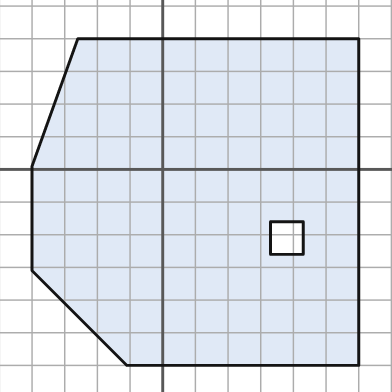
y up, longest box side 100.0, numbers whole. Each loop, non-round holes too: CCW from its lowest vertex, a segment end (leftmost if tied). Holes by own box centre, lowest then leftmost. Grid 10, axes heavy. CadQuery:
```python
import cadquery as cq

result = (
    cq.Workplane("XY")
    .moveTo(-11.0, -60.0)
    .lineTo(60.0, -60.0)
    .lineTo(60.0, 40.0)
    .lineTo(-26.0, 40.0)
    .lineTo(-40.0, 1.0)
    .lineTo(-40.0, -31.0)
    .close()
    .moveTo(33.0, -26.0)
    .lineTo(43.0, -26.0)
    .lineTo(43.0, -16.0)
    .lineTo(33.0, -16.0)
    .close()
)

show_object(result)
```